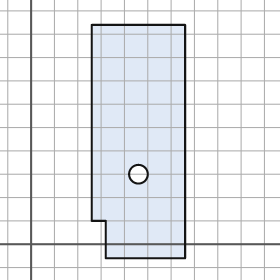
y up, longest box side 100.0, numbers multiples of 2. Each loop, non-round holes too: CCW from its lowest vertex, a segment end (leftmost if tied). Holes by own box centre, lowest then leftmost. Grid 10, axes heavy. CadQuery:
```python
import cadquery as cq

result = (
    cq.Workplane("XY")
    .moveTo(32.0, -6.0)
    .lineTo(66.0, -6.0)
    .lineTo(66.0, 94.0)
    .lineTo(26.0, 94.0)
    .lineTo(26.0, 10.0)
    .lineTo(32.0, 10.0)
    .close()
    .moveTo(46.0, 30.0)
    .circle(4.0)
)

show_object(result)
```